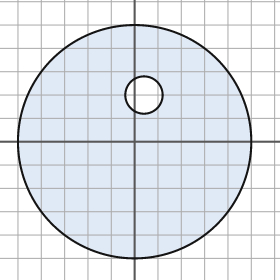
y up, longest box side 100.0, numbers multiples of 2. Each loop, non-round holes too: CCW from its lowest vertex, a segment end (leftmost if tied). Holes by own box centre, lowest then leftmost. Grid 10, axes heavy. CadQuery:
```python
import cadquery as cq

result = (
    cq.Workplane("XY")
    .moveTo(0.0, 0.0)
    .circle(50.0)
    .moveTo(4.0, 20.0)
    .circle(8.0)
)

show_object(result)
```